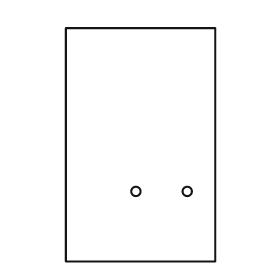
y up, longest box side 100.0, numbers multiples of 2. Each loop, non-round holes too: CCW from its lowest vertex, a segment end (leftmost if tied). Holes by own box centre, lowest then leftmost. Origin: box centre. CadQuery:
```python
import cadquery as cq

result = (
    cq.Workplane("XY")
    .moveTo(-32.0, -50.0)
    .lineTo(32.0, -50.0)
    .lineTo(32.0, 50.0)
    .lineTo(-32.0, 50.0)
    .close()
    .moveTo(-2.0, -20.0)
    .circle(2.0)
    .moveTo(20.0, -20.0)
    .circle(2.0)
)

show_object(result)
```